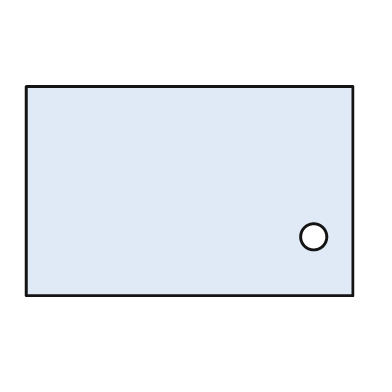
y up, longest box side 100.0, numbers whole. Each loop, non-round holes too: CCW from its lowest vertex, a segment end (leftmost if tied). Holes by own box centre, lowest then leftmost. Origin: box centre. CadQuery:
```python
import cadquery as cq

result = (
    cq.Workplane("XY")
    .moveTo(-50.0, -32.0)
    .lineTo(50.0, -32.0)
    .lineTo(50.0, 32.0)
    .lineTo(-50.0, 32.0)
    .close()
    .moveTo(38.0, -14.0)
    .circle(4.0)
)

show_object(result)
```